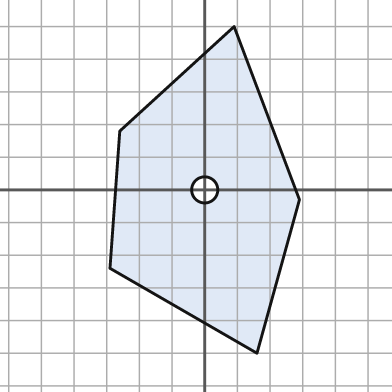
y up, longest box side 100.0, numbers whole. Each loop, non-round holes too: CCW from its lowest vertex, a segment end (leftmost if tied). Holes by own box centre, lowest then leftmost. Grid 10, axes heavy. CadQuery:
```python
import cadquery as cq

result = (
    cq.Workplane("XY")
    .moveTo(16.0, -50.0)
    .lineTo(29.0, -3.0)
    .lineTo(9.0, 50.0)
    .lineTo(-26.0, 18.0)
    .lineTo(-29.0, -24.0)
    .close()
    .moveTo(0.0, 0.0)
    .circle(4.0)
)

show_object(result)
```